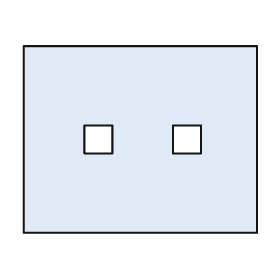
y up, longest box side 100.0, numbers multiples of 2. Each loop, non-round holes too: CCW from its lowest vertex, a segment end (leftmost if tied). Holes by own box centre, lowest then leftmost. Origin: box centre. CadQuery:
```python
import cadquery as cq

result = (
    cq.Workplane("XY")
    .moveTo(-50.0, -40.0)
    .lineTo(50.0, -40.0)
    .lineTo(50.0, 40.0)
    .lineTo(-50.0, 40.0)
    .close()
    .moveTo(-24.0, -6.0)
    .lineTo(-12.0, -6.0)
    .lineTo(-12.0, 6.0)
    .lineTo(-24.0, 6.0)
    .close()
    .moveTo(14.0, -6.0)
    .lineTo(26.0, -6.0)
    .lineTo(26.0, 6.0)
    .lineTo(14.0, 6.0)
    .close()
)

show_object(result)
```